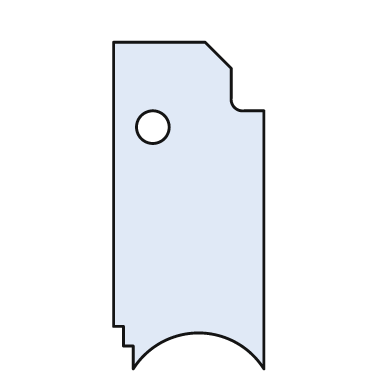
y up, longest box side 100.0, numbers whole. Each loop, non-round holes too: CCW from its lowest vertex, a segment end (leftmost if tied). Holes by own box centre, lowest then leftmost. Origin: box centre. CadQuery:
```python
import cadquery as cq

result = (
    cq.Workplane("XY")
    .moveTo(-17.0, -50.0)
    .threePointArc((3.0, -39.0), (23.0, -50.0))
    .lineTo(23.0, 29.0)
    .lineTo(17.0, 29.0)
    .threePointArc((14.0, 30.0), (13.0, 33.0))
    .lineTo(13.0, 42.0)
    .lineTo(5.0, 50.0)
    .lineTo(-23.0, 50.0)
    .lineTo(-23.0, -37.0)
    .lineTo(-20.0, -37.0)
    .lineTo(-20.0, -43.0)
    .lineTo(-17.0, -43.0)
    .close()
    .moveTo(-11.0, 24.0)
    .circle(5.0)
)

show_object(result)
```